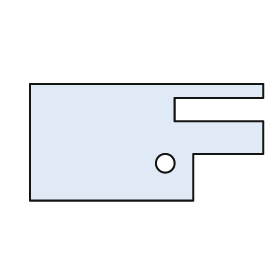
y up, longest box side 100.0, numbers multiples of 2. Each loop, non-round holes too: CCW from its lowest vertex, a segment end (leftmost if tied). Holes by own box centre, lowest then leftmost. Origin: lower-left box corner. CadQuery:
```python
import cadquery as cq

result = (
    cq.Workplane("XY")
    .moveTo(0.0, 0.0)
    .lineTo(70.0, 0.0)
    .lineTo(70.0, 20.0)
    .lineTo(100.0, 20.0)
    .lineTo(100.0, 34.0)
    .lineTo(62.0, 34.0)
    .lineTo(62.0, 44.0)
    .lineTo(100.0, 44.0)
    .lineTo(100.0, 50.0)
    .lineTo(0.0, 50.0)
    .close()
    .moveTo(58.0, 16.0)
    .circle(4.0)
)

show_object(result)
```